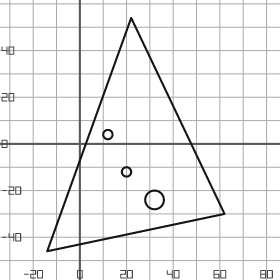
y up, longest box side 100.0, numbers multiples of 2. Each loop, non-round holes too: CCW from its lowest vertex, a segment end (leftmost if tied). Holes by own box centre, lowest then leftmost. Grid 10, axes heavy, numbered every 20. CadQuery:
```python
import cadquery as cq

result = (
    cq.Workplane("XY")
    .moveTo(-14.0, -46.0)
    .lineTo(62.0, -30.0)
    .lineTo(22.0, 54.0)
    .close()
    .moveTo(32.0, -24.0)
    .circle(4.0)
    .moveTo(20.0, -12.0)
    .circle(2.0)
    .moveTo(12.0, 4.0)
    .circle(2.0)
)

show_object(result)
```